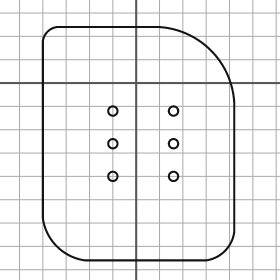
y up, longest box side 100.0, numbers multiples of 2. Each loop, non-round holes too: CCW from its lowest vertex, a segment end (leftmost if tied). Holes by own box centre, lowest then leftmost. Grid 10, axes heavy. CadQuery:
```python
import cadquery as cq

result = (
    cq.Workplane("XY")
    .moveTo(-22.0, -76.0)
    .lineTo(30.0, -76.0)
    .threePointArc((38.0, -72.0), (42.0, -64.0))
    .lineTo(42.0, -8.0)
    .threePointArc((32.0, 14.0), (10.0, 24.0))
    .lineTo(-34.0, 24.0)
    .threePointArc((-38.0, 22.0), (-40.0, 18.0))
    .lineTo(-40.0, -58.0)
    .threePointArc((-34.0, -70.0), (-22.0, -76.0))
    .close()
    .moveTo(-10.0, -40.0)
    .circle(2.0)
    .moveTo(16.0, -40.0)
    .circle(2.0)
    .moveTo(-10.0, -26.0)
    .circle(2.0)
    .moveTo(16.0, -26.0)
    .circle(2.0)
    .moveTo(-10.0, -12.0)
    .circle(2.0)
    .moveTo(16.0, -12.0)
    .circle(2.0)
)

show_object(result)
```